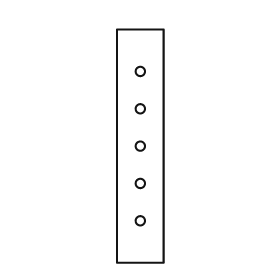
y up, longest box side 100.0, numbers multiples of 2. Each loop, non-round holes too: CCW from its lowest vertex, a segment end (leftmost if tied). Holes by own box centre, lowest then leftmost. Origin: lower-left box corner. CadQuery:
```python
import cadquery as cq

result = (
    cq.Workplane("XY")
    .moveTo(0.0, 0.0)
    .lineTo(20.0, 0.0)
    .lineTo(20.0, 100.0)
    .lineTo(0.0, 100.0)
    .close()
    .moveTo(10.0, 18.0)
    .circle(2.0)
    .moveTo(10.0, 34.0)
    .circle(2.0)
    .moveTo(10.0, 50.0)
    .circle(2.0)
    .moveTo(10.0, 66.0)
    .circle(2.0)
    .moveTo(10.0, 82.0)
    .circle(2.0)
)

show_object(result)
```